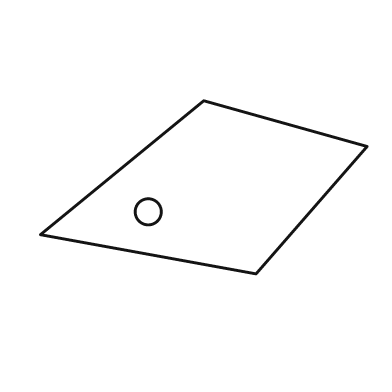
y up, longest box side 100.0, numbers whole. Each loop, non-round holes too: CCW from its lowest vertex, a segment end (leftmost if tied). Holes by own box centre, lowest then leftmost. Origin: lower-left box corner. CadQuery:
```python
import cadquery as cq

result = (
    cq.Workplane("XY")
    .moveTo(66.0, 0.0)
    .lineTo(100.0, 39.0)
    .lineTo(50.0, 53.0)
    .lineTo(0.0, 12.0)
    .close()
    .moveTo(33.0, 19.0)
    .circle(4.0)
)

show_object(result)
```